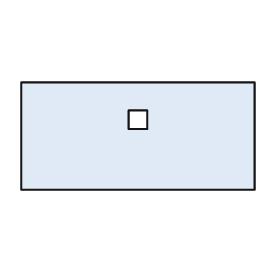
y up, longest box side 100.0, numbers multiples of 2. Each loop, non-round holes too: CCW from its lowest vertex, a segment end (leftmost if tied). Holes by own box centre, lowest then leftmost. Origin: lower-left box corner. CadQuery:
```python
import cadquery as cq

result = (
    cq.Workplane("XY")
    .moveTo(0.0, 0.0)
    .lineTo(100.0, 0.0)
    .lineTo(100.0, 46.0)
    .lineTo(0.0, 46.0)
    .close()
    .moveTo(46.0, 26.0)
    .lineTo(54.0, 26.0)
    .lineTo(54.0, 34.0)
    .lineTo(46.0, 34.0)
    .close()
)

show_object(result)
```